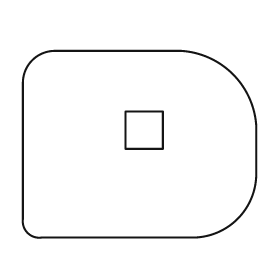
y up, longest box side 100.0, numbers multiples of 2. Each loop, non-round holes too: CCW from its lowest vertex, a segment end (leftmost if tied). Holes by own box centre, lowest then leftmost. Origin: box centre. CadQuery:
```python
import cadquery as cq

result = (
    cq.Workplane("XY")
    .moveTo(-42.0, -40.0)
    .lineTo(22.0, -40.0)
    .threePointArc((42.0, -32.0), (50.0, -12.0))
    .lineTo(50.0, 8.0)
    .threePointArc((40.0, 30.0), (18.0, 40.0))
    .lineTo(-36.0, 40.0)
    .threePointArc((-46.0, 36.0), (-50.0, 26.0))
    .lineTo(-50.0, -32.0)
    .threePointArc((-48.0, -38.0), (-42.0, -40.0))
    .close()
    .moveTo(-6.0, -2.0)
    .lineTo(10.0, -2.0)
    .lineTo(10.0, 14.0)
    .lineTo(-6.0, 14.0)
    .close()
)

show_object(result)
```